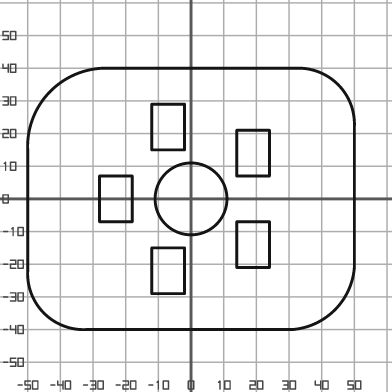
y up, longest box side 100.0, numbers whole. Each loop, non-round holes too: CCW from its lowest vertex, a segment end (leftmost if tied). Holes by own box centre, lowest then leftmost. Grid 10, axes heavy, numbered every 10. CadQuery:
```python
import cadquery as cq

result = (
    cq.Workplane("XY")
    .moveTo(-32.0, -40.0)
    .lineTo(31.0, -40.0)
    .threePointArc((44.0, -34.0), (50.0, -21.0))
    .lineTo(50.0, 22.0)
    .threePointArc((45.0, 35.0), (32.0, 40.0))
    .lineTo(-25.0, 40.0)
    .threePointArc((-43.0, 33.0), (-50.0, 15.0))
    .lineTo(-50.0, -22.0)
    .threePointArc((-45.0, -35.0), (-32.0, -40.0))
    .close()
    .moveTo(-12.0, -29.0)
    .lineTo(-2.0, -29.0)
    .lineTo(-2.0, -15.0)
    .lineTo(-12.0, -15.0)
    .close()
    .moveTo(14.0, -21.0)
    .lineTo(24.0, -21.0)
    .lineTo(24.0, -7.0)
    .lineTo(14.0, -7.0)
    .close()
    .moveTo(-28.0, -7.0)
    .lineTo(-18.0, -7.0)
    .lineTo(-18.0, 7.0)
    .lineTo(-28.0, 7.0)
    .close()
    .moveTo(0.0, 0.0)
    .circle(11.0)
    .moveTo(14.0, 7.0)
    .lineTo(24.0, 7.0)
    .lineTo(24.0, 21.0)
    .lineTo(14.0, 21.0)
    .close()
    .moveTo(-12.0, 15.0)
    .lineTo(-2.0, 15.0)
    .lineTo(-2.0, 29.0)
    .lineTo(-12.0, 29.0)
    .close()
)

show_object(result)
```